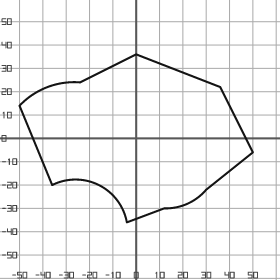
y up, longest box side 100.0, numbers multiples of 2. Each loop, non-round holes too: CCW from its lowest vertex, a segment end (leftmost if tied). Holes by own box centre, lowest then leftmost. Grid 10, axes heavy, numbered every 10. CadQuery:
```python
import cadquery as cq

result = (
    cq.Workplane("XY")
    .moveTo(-4.0, -36.0)
    .lineTo(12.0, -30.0)
    .threePointArc((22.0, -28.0), (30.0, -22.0))
    .lineTo(50.0, -6.0)
    .lineTo(36.0, 22.0)
    .lineTo(0.0, 36.0)
    .lineTo(-24.0, 24.0)
    .threePointArc((-38.0, 22.0), (-50.0, 14.0))
    .lineTo(-36.0, -20.0)
    .threePointArc((-16.0, -20.0), (-4.0, -36.0))
    .close()
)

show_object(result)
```